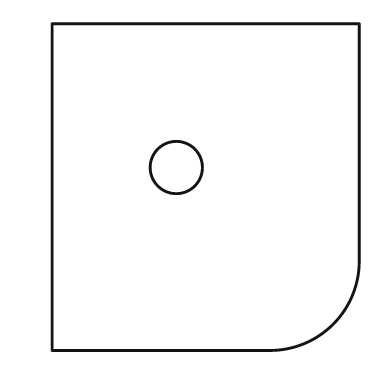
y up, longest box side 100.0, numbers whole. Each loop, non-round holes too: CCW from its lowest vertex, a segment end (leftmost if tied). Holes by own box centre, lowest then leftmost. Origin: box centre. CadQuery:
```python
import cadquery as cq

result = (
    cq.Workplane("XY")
    .moveTo(-47.0, -50.0)
    .lineTo(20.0, -50.0)
    .threePointArc((39.0, -42.0), (47.0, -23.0))
    .lineTo(47.0, 50.0)
    .lineTo(-47.0, 50.0)
    .close()
    .moveTo(-9.0, 6.0)
    .circle(8.0)
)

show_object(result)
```